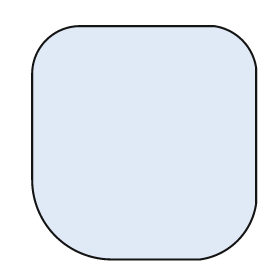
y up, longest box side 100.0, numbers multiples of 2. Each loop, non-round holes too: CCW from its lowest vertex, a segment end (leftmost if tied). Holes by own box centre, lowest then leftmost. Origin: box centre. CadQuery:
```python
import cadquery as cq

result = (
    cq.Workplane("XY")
    .moveTo(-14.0, -50.0)
    .lineTo(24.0, -50.0)
    .threePointArc((40.0, -42.0), (48.0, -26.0))
    .lineTo(48.0, 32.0)
    .threePointArc((42.0, 44.0), (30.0, 50.0))
    .lineTo(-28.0, 50.0)
    .threePointArc((-42.0, 44.0), (-48.0, 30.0))
    .lineTo(-48.0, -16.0)
    .threePointArc((-38.0, -40.0), (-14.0, -50.0))
    .close()
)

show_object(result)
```